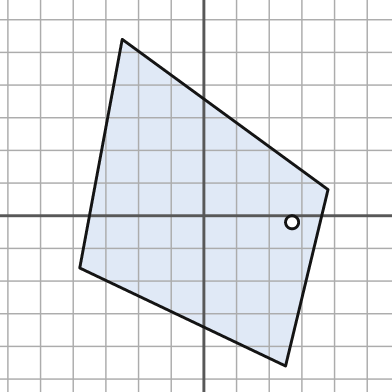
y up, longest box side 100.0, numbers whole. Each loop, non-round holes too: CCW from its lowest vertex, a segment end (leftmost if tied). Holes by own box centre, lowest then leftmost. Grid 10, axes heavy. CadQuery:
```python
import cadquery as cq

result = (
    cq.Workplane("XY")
    .moveTo(25.0, -46.0)
    .lineTo(38.0, 8.0)
    .lineTo(-25.0, 54.0)
    .lineTo(-38.0, -16.0)
    .close()
    .moveTo(27.0, -2.0)
    .circle(2.0)
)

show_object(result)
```